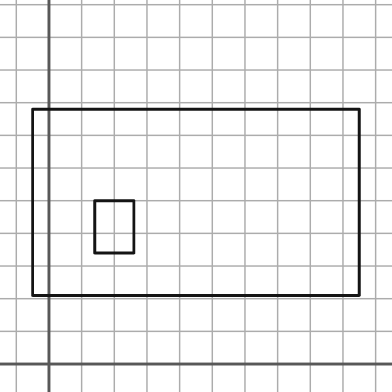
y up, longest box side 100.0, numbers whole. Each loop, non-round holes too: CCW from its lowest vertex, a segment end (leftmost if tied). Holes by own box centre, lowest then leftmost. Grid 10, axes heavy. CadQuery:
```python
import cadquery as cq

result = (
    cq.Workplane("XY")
    .moveTo(-5.0, 21.0)
    .lineTo(95.0, 21.0)
    .lineTo(95.0, 78.0)
    .lineTo(-5.0, 78.0)
    .close()
    .moveTo(14.0, 34.0)
    .lineTo(26.0, 34.0)
    .lineTo(26.0, 50.0)
    .lineTo(14.0, 50.0)
    .close()
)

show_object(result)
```